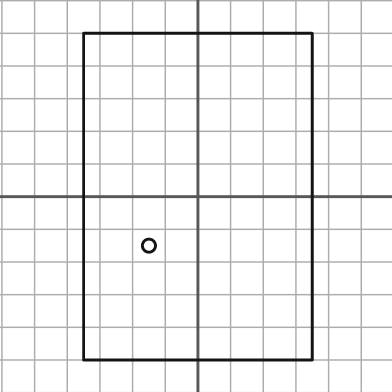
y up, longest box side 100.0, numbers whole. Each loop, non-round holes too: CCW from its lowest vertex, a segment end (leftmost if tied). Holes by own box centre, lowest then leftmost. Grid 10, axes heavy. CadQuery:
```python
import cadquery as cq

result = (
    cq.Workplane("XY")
    .moveTo(-35.0, -50.0)
    .lineTo(35.0, -50.0)
    .lineTo(35.0, 50.0)
    .lineTo(-35.0, 50.0)
    .close()
    .moveTo(-15.0, -15.0)
    .circle(2.0)
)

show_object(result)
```